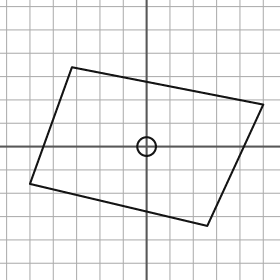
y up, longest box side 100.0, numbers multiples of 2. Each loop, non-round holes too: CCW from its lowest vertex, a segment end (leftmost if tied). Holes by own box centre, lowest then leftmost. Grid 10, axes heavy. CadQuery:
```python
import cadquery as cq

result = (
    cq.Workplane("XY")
    .moveTo(26.0, -34.0)
    .lineTo(50.0, 18.0)
    .lineTo(-32.0, 34.0)
    .lineTo(-50.0, -16.0)
    .close()
    .moveTo(0.0, 0.0)
    .circle(4.0)
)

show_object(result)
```